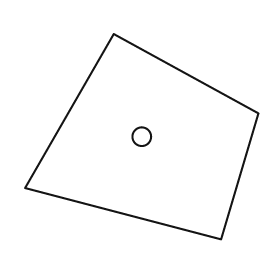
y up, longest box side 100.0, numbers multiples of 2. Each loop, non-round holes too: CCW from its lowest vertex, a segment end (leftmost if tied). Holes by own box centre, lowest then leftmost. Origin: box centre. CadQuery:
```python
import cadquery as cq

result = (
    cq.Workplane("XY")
    .moveTo(34.0, -44.0)
    .lineTo(50.0, 10.0)
    .lineTo(-12.0, 44.0)
    .lineTo(-50.0, -22.0)
    .close()
    .moveTo(0.0, 0.0)
    .circle(4.0)
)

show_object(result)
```